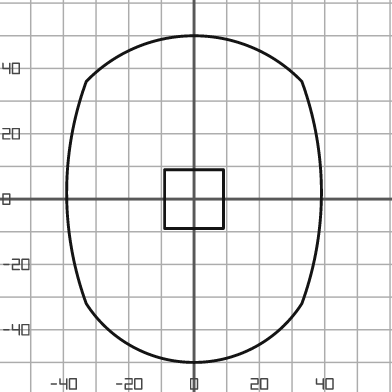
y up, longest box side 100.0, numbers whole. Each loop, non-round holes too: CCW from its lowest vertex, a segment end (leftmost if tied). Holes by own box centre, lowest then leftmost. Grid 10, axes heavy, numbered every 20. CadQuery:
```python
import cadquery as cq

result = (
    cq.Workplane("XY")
    .moveTo(-33.0, -32.0)
    .threePointArc((0.0, -50.0), (33.0, -32.0))
    .threePointArc((39.0, 2.0), (33.0, 36.0))
    .threePointArc((0.0, 50.0), (-33.0, 36.0))
    .threePointArc((-39.0, 2.0), (-33.0, -32.0))
    .close()
    .moveTo(-9.0, -9.0)
    .lineTo(9.0, -9.0)
    .lineTo(9.0, 9.0)
    .lineTo(-9.0, 9.0)
    .close()
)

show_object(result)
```